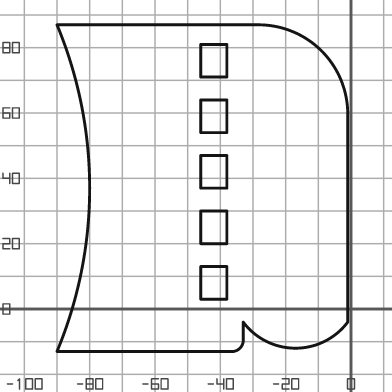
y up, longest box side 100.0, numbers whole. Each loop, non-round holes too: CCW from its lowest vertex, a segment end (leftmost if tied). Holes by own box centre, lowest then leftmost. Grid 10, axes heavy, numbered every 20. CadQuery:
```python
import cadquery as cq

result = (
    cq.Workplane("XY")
    .moveTo(-90.0, -13.0)
    .lineTo(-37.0, -13.0)
    .threePointArc((-34.0, -12.0), (-33.0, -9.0))
    .lineTo(-33.0, -4.0)
    .threePointArc((-17.0, -12.0), (-1.0, -4.0))
    .lineTo(-1.0, 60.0)
    .threePointArc((-9.0, 79.0), (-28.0, 87.0))
    .lineTo(-90.0, 87.0)
    .threePointArc((-80.0, 37.0), (-90.0, -13.0))
    .close()
    .moveTo(-46.0, 3.0)
    .lineTo(-38.0, 3.0)
    .lineTo(-38.0, 13.0)
    .lineTo(-46.0, 13.0)
    .close()
    .moveTo(-46.0, 20.0)
    .lineTo(-38.0, 20.0)
    .lineTo(-38.0, 30.0)
    .lineTo(-46.0, 30.0)
    .close()
    .moveTo(-46.0, 37.0)
    .lineTo(-38.0, 37.0)
    .lineTo(-38.0, 47.0)
    .lineTo(-46.0, 47.0)
    .close()
    .moveTo(-46.0, 54.0)
    .lineTo(-38.0, 54.0)
    .lineTo(-38.0, 64.0)
    .lineTo(-46.0, 64.0)
    .close()
    .moveTo(-46.0, 71.0)
    .lineTo(-38.0, 71.0)
    .lineTo(-38.0, 81.0)
    .lineTo(-46.0, 81.0)
    .close()
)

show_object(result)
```